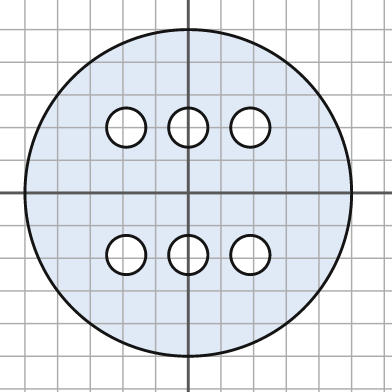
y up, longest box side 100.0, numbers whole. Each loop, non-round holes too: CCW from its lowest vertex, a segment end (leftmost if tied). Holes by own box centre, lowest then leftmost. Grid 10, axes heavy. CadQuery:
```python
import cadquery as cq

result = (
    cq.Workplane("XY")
    .moveTo(0.0, 0.0)
    .circle(50.0)
    .moveTo(-19.0, -19.0)
    .circle(6.0)
    .moveTo(0.0, -19.0)
    .circle(6.0)
    .moveTo(19.0, -19.0)
    .circle(6.0)
    .moveTo(-19.0, 20.0)
    .circle(6.0)
    .moveTo(0.0, 20.0)
    .circle(6.0)
    .moveTo(19.0, 20.0)
    .circle(6.0)
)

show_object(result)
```